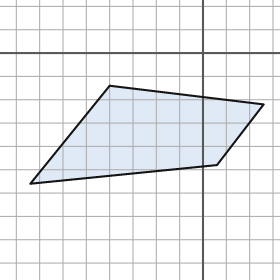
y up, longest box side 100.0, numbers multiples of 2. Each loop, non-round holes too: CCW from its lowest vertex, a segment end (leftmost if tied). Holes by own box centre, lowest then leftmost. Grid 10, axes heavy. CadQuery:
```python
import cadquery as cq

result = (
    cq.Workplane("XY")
    .moveTo(-74.0, -56.0)
    .lineTo(6.0, -48.0)
    .lineTo(26.0, -22.0)
    .lineTo(-40.0, -14.0)
    .close()
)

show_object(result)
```